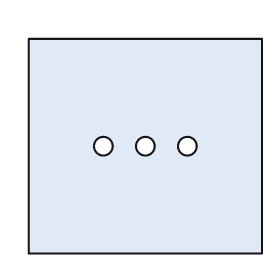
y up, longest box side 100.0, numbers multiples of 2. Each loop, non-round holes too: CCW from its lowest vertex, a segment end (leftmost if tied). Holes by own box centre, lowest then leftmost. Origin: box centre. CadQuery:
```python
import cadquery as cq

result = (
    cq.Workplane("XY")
    .moveTo(-50.0, -46.0)
    .lineTo(50.0, -46.0)
    .lineTo(50.0, 46.0)
    .lineTo(-50.0, 46.0)
    .close()
    .moveTo(-18.0, 0.0)
    .circle(4.0)
    .moveTo(0.0, 0.0)
    .circle(4.0)
    .moveTo(18.0, 0.0)
    .circle(4.0)
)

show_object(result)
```